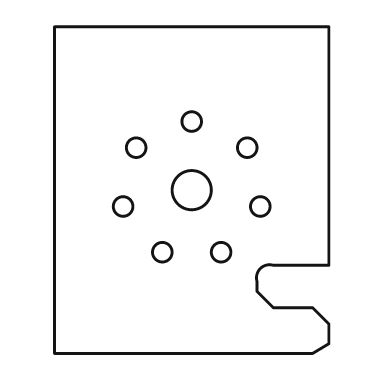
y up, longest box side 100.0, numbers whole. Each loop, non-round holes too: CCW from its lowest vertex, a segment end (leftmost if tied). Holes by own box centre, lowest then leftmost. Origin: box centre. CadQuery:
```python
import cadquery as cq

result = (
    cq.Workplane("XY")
    .moveTo(-42.0, -50.0)
    .lineTo(37.0, -50.0)
    .lineTo(42.0, -47.0)
    .lineTo(42.0, -41.0)
    .lineTo(37.0, -36.0)
    .lineTo(25.0, -36.0)
    .lineTo(20.0, -31.0)
    .lineTo(20.0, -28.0)
    .threePointArc((21.0, -24.0), (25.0, -23.0))
    .lineTo(42.0, -23.0)
    .lineTo(42.0, 50.0)
    .lineTo(-42.0, 50.0)
    .close()
    .moveTo(-9.0, -19.0)
    .circle(3.0)
    .moveTo(9.0, -19.0)
    .circle(3.0)
    .moveTo(-21.0, -5.0)
    .circle(3.0)
    .moveTo(21.0, -5.0)
    .circle(3.0)
    .moveTo(0.0, 0.0)
    .circle(6.0)
    .moveTo(-17.0, 13.0)
    .circle(3.0)
    .moveTo(17.0, 13.0)
    .circle(3.0)
    .moveTo(0.0, 21.0)
    .circle(3.0)
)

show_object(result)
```